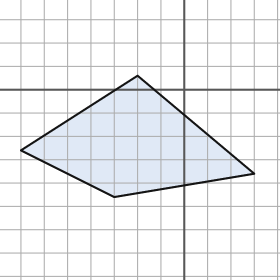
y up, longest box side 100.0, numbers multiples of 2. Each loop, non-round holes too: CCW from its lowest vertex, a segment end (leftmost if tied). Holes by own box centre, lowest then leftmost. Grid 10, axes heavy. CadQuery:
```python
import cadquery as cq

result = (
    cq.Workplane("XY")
    .moveTo(-30.0, -46.0)
    .lineTo(30.0, -36.0)
    .lineTo(-20.0, 6.0)
    .lineTo(-70.0, -26.0)
    .close()
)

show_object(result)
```